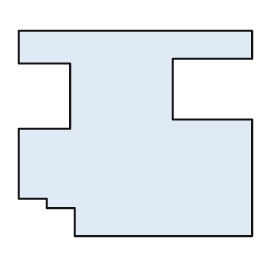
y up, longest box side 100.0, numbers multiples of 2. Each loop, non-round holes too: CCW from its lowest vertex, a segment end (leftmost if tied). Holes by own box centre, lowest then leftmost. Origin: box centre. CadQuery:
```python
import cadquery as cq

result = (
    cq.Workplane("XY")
    .moveTo(-26.0, -44.0)
    .lineTo(50.0, -44.0)
    .lineTo(50.0, 6.0)
    .lineTo(16.0, 6.0)
    .lineTo(16.0, 32.0)
    .lineTo(50.0, 32.0)
    .lineTo(50.0, 44.0)
    .lineTo(-50.0, 44.0)
    .lineTo(-50.0, 30.0)
    .lineTo(-28.0, 30.0)
    .lineTo(-28.0, 2.0)
    .lineTo(-50.0, 2.0)
    .lineTo(-50.0, -28.0)
    .lineTo(-38.0, -28.0)
    .lineTo(-38.0, -32.0)
    .lineTo(-26.0, -32.0)
    .close()
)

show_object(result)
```